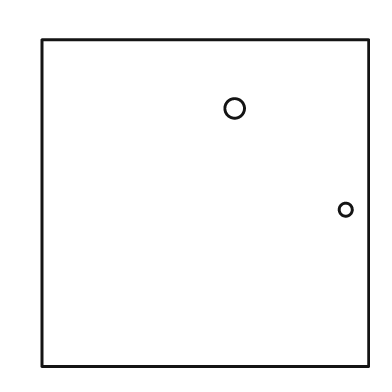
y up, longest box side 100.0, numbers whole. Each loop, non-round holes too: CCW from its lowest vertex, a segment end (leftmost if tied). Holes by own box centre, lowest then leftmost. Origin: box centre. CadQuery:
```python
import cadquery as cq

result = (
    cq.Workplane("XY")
    .moveTo(-50.0, -50.0)
    .lineTo(50.0, -50.0)
    .lineTo(50.0, 50.0)
    .lineTo(-50.0, 50.0)
    .close()
    .moveTo(43.0, -2.0)
    .circle(2.0)
    .moveTo(9.0, 29.0)
    .circle(3.0)
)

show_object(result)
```